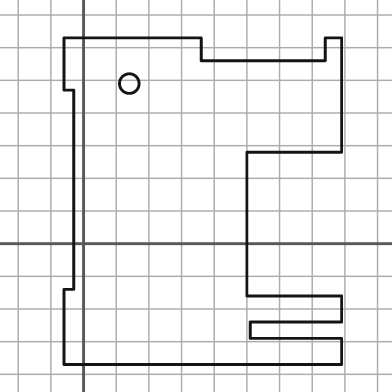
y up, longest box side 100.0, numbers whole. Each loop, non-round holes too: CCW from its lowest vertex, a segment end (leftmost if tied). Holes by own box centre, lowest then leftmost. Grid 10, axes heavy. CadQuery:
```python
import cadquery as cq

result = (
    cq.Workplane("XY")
    .moveTo(-6.0, -37.0)
    .lineTo(79.0, -37.0)
    .lineTo(79.0, -29.0)
    .lineTo(51.0, -29.0)
    .lineTo(51.0, -24.0)
    .lineTo(79.0, -24.0)
    .lineTo(79.0, -16.0)
    .lineTo(50.0, -16.0)
    .lineTo(50.0, 28.0)
    .lineTo(79.0, 28.0)
    .lineTo(79.0, 63.0)
    .lineTo(74.0, 63.0)
    .lineTo(74.0, 56.0)
    .lineTo(36.0, 56.0)
    .lineTo(36.0, 63.0)
    .lineTo(-6.0, 63.0)
    .lineTo(-6.0, 47.0)
    .lineTo(-3.0, 47.0)
    .lineTo(-3.0, -14.0)
    .lineTo(-6.0, -14.0)
    .close()
    .moveTo(14.0, 49.0)
    .circle(3.0)
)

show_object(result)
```